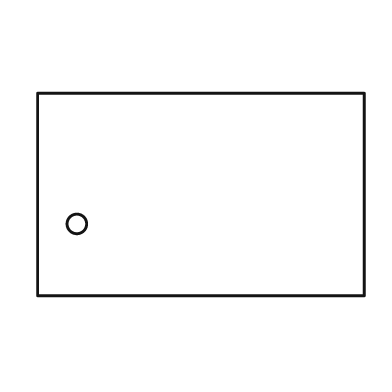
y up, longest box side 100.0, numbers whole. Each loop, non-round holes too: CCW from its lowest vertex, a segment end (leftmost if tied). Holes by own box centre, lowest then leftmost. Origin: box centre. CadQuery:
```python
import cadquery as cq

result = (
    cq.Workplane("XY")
    .moveTo(-50.0, -31.0)
    .lineTo(50.0, -31.0)
    .lineTo(50.0, 31.0)
    .lineTo(-50.0, 31.0)
    .close()
    .moveTo(-38.0, -9.0)
    .circle(3.0)
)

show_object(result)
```